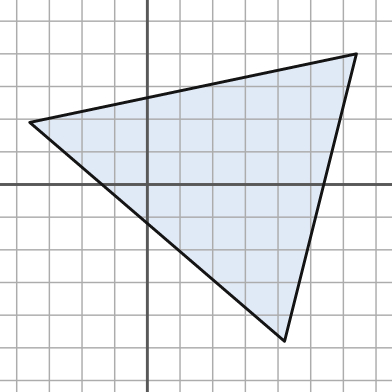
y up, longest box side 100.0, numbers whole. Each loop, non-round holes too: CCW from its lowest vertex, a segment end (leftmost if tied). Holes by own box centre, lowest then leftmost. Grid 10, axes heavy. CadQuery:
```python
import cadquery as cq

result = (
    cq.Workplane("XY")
    .moveTo(42.0, -48.0)
    .lineTo(64.0, 40.0)
    .lineTo(-36.0, 19.0)
    .close()
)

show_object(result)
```